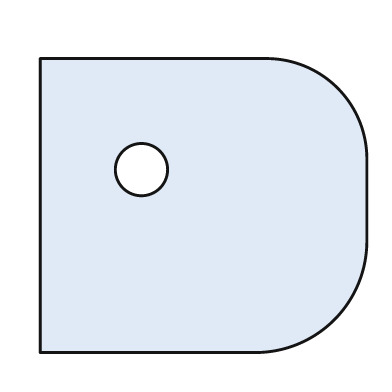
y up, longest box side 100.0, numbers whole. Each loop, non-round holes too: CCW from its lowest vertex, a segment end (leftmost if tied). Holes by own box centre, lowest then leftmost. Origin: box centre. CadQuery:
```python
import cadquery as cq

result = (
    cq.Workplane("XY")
    .moveTo(-50.0, -45.0)
    .lineTo(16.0, -45.0)
    .threePointArc((40.0, -35.0), (50.0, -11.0))
    .lineTo(50.0, 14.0)
    .threePointArc((41.0, 36.0), (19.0, 45.0))
    .lineTo(-50.0, 45.0)
    .close()
    .moveTo(-19.0, 11.0)
    .circle(8.0)
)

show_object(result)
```